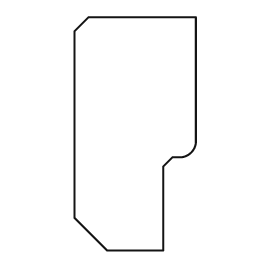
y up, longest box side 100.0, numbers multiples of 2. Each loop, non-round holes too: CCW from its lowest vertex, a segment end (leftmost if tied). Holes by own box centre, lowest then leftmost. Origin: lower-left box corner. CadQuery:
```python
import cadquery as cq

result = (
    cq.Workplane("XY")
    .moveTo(14.0, 0.0)
    .lineTo(38.0, 0.0)
    .lineTo(38.0, 36.0)
    .lineTo(42.0, 40.0)
    .lineTo(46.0, 40.0)
    .threePointArc((50.0, 42.0), (52.0, 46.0))
    .lineTo(52.0, 100.0)
    .lineTo(6.0, 100.0)
    .lineTo(0.0, 94.0)
    .lineTo(0.0, 14.0)
    .close()
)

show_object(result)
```